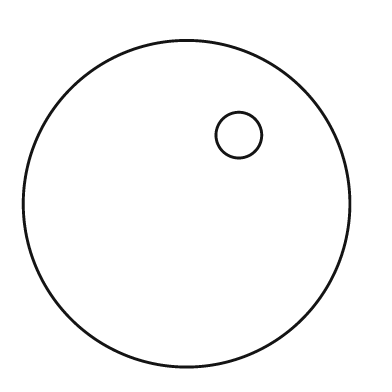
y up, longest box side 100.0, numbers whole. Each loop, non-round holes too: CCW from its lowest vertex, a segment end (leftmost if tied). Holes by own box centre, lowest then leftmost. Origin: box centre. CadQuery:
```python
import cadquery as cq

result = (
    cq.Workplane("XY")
    .moveTo(0.0, 0.0)
    .circle(50.0)
    .moveTo(16.0, 21.0)
    .circle(7.0)
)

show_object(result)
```